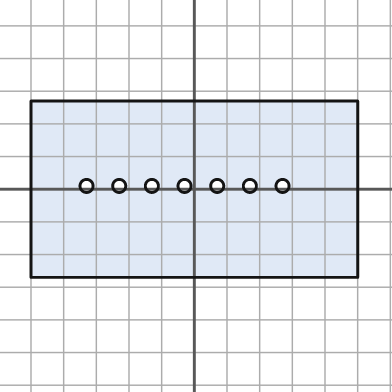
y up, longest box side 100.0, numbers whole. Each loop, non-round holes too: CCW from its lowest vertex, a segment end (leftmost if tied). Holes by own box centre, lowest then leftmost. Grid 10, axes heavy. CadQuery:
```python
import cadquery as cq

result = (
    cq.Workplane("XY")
    .moveTo(-50.0, -27.0)
    .lineTo(50.0, -27.0)
    .lineTo(50.0, 27.0)
    .lineTo(-50.0, 27.0)
    .close()
    .moveTo(-33.0, 1.0)
    .circle(2.0)
    .moveTo(-23.0, 1.0)
    .circle(2.0)
    .moveTo(-13.0, 1.0)
    .circle(2.0)
    .moveTo(-3.0, 1.0)
    .circle(2.0)
    .moveTo(7.0, 1.0)
    .circle(2.0)
    .moveTo(17.0, 1.0)
    .circle(2.0)
    .moveTo(27.0, 1.0)
    .circle(2.0)
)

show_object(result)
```